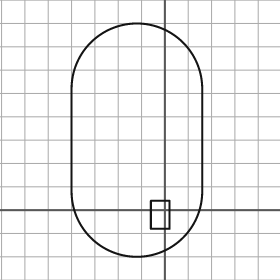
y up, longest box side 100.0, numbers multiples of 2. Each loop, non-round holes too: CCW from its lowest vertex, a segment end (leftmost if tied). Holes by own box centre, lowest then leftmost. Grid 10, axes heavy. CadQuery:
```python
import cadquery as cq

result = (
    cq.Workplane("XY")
    .moveTo(-40.0, 8.0)
    .threePointArc((-12.0, -20.0), (16.0, 8.0))
    .lineTo(16.0, 52.0)
    .threePointArc((-12.0, 80.0), (-40.0, 52.0))
    .close()
    .moveTo(-6.0, -8.0)
    .lineTo(2.0, -8.0)
    .lineTo(2.0, 4.0)
    .lineTo(-6.0, 4.0)
    .close()
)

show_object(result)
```